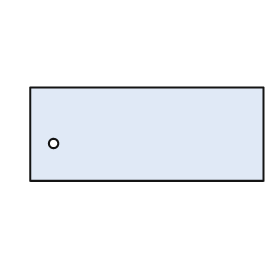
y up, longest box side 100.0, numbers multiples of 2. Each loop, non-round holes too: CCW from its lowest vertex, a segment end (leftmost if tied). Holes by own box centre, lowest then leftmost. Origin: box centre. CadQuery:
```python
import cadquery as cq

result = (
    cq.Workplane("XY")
    .moveTo(-50.0, -20.0)
    .lineTo(50.0, -20.0)
    .lineTo(50.0, 20.0)
    .lineTo(-50.0, 20.0)
    .close()
    .moveTo(-40.0, -4.0)
    .circle(2.0)
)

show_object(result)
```